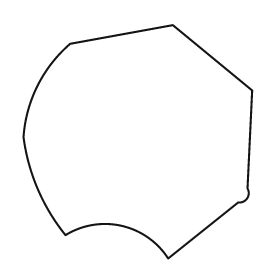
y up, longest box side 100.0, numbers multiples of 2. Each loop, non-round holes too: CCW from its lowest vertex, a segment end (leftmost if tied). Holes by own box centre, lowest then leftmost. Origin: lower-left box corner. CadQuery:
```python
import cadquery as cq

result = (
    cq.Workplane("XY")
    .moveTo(62.0, 0.0)
    .lineTo(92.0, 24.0)
    .threePointArc((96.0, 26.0), (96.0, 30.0))
    .lineTo(98.0, 72.0)
    .lineTo(64.0, 100.0)
    .lineTo(20.0, 92.0)
    .threePointArc((6.0, 74.0), (0.0, 52.0))
    .threePointArc((6.0, 30.0), (18.0, 10.0))
    .threePointArc((42.0, 14.0), (62.0, 0.0))
    .close()
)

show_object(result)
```